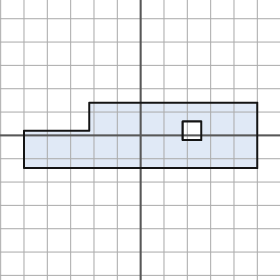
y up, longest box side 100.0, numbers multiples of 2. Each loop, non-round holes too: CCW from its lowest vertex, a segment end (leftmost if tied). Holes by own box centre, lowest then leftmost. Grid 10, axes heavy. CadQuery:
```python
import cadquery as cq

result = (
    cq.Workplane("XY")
    .moveTo(-50.0, -14.0)
    .lineTo(50.0, -14.0)
    .lineTo(50.0, 14.0)
    .lineTo(-22.0, 14.0)
    .lineTo(-22.0, 2.0)
    .lineTo(-50.0, 2.0)
    .close()
    .moveTo(18.0, -2.0)
    .lineTo(26.0, -2.0)
    .lineTo(26.0, 6.0)
    .lineTo(18.0, 6.0)
    .close()
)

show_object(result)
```